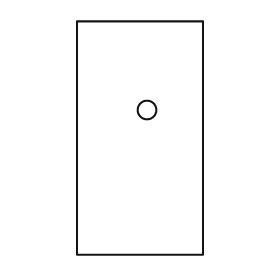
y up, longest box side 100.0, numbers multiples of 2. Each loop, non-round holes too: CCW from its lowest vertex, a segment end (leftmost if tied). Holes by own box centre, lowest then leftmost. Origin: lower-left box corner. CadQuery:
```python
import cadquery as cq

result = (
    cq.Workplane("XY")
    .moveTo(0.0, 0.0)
    .lineTo(54.0, 0.0)
    .lineTo(54.0, 100.0)
    .lineTo(0.0, 100.0)
    .close()
    .moveTo(30.0, 62.0)
    .circle(4.0)
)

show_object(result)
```